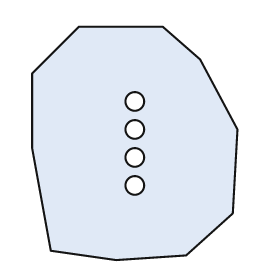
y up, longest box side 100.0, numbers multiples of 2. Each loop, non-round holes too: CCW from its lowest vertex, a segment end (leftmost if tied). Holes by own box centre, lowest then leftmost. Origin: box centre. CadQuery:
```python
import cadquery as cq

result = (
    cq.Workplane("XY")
    .moveTo(-8.0, -50.0)
    .lineTo(22.0, -48.0)
    .lineTo(42.0, -30.0)
    .lineTo(44.0, 6.0)
    .lineTo(28.0, 36.0)
    .lineTo(12.0, 50.0)
    .lineTo(-24.0, 50.0)
    .lineTo(-44.0, 30.0)
    .lineTo(-44.0, -2.0)
    .lineTo(-36.0, -46.0)
    .close()
    .moveTo(0.0, -18.0)
    .circle(4.0)
    .moveTo(0.0, -6.0)
    .circle(4.0)
    .moveTo(0.0, 6.0)
    .circle(4.0)
    .moveTo(0.0, 18.0)
    .circle(4.0)
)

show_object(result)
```